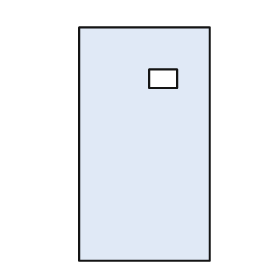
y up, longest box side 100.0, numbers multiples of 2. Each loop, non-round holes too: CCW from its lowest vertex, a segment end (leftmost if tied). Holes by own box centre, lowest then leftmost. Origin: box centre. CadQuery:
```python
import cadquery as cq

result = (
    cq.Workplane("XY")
    .moveTo(-28.0, -50.0)
    .lineTo(28.0, -50.0)
    .lineTo(28.0, 50.0)
    .lineTo(-28.0, 50.0)
    .close()
    .moveTo(2.0, 24.0)
    .lineTo(14.0, 24.0)
    .lineTo(14.0, 32.0)
    .lineTo(2.0, 32.0)
    .close()
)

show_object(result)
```